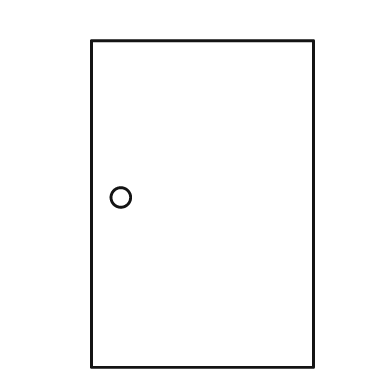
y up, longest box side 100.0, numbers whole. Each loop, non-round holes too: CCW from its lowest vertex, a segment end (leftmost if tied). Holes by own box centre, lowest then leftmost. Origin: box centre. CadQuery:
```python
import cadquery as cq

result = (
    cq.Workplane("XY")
    .moveTo(-34.0, -50.0)
    .lineTo(34.0, -50.0)
    .lineTo(34.0, 50.0)
    .lineTo(-34.0, 50.0)
    .close()
    .moveTo(-25.0, 2.0)
    .circle(3.0)
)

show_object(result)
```